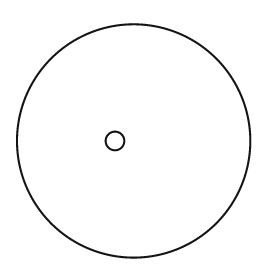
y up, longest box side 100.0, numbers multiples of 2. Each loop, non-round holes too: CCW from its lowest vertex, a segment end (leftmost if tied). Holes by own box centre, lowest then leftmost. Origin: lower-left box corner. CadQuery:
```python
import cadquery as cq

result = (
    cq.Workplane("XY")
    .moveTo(50.0, 50.0)
    .circle(50.0)
    .moveTo(42.0, 50.0)
    .circle(4.0)
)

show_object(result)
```